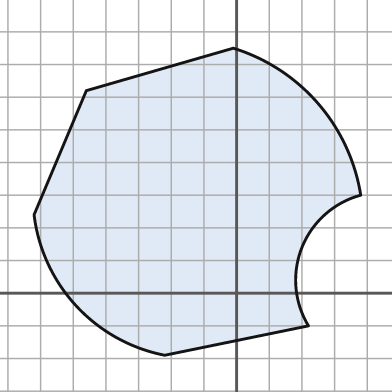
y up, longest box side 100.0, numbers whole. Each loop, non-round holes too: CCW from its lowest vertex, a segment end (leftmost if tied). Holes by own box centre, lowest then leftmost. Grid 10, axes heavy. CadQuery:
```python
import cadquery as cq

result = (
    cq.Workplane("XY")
    .moveTo(-22.0, -19.0)
    .lineTo(22.0, -10.0)
    .threePointArc((20.0, 14.0), (38.0, 30.0))
    .threePointArc((25.0, 58.0), (-1.0, 75.0))
    .lineTo(-46.0, 62.0)
    .lineTo(-62.0, 24.0)
    .threePointArc((-49.0, -4.0), (-22.0, -19.0))
    .close()
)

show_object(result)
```